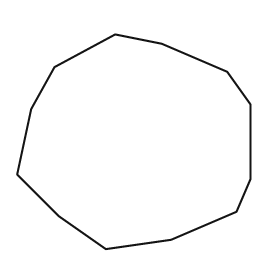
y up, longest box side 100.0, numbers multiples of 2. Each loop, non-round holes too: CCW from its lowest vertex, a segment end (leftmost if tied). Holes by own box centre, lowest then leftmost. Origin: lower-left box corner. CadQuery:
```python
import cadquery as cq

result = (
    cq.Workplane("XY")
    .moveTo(38.0, 0.0)
    .lineTo(66.0, 4.0)
    .lineTo(94.0, 16.0)
    .lineTo(100.0, 30.0)
    .lineTo(100.0, 62.0)
    .lineTo(90.0, 76.0)
    .lineTo(62.0, 88.0)
    .lineTo(42.0, 92.0)
    .lineTo(16.0, 78.0)
    .lineTo(6.0, 60.0)
    .lineTo(0.0, 32.0)
    .lineTo(18.0, 14.0)
    .close()
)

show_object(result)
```